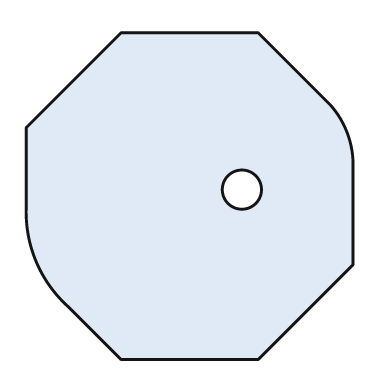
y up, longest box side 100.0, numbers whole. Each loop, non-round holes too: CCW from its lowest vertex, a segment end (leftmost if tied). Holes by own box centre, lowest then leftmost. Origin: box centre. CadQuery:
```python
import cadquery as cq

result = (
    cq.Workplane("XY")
    .moveTo(-21.0, -50.0)
    .lineTo(21.0, -50.0)
    .lineTo(50.0, -21.0)
    .lineTo(50.0, 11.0)
    .threePointArc((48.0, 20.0), (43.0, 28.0))
    .lineTo(21.0, 50.0)
    .lineTo(-21.0, 50.0)
    .lineTo(-50.0, 21.0)
    .lineTo(-50.0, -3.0)
    .threePointArc((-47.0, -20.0), (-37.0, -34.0))
    .close()
    .moveTo(16.0, 2.0)
    .circle(6.0)
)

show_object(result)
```